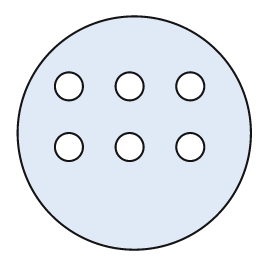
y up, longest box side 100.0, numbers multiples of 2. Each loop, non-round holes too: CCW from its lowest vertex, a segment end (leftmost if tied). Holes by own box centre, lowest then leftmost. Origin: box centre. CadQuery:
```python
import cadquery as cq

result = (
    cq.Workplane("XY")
    .moveTo(0.0, 0.0)
    .circle(50.0)
    .moveTo(-28.0, -6.0)
    .circle(6.0)
    .moveTo(-2.0, -6.0)
    .circle(6.0)
    .moveTo(24.0, -6.0)
    .circle(6.0)
    .moveTo(-28.0, 20.0)
    .circle(6.0)
    .moveTo(-2.0, 20.0)
    .circle(6.0)
    .moveTo(24.0, 20.0)
    .circle(6.0)
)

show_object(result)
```